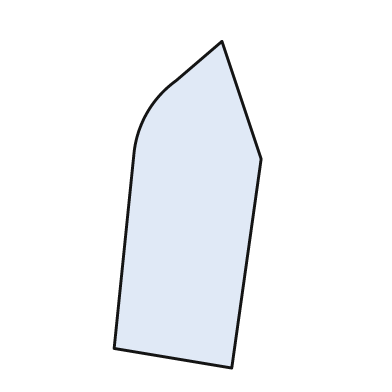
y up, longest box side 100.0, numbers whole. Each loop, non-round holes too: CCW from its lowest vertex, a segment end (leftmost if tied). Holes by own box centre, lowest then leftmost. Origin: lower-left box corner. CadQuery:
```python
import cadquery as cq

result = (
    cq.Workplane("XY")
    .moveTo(36.0, 0.0)
    .lineTo(45.0, 64.0)
    .lineTo(33.0, 100.0)
    .lineTo(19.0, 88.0)
    .threePointArc((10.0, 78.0), (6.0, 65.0))
    .lineTo(0.0, 6.0)
    .close()
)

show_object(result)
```